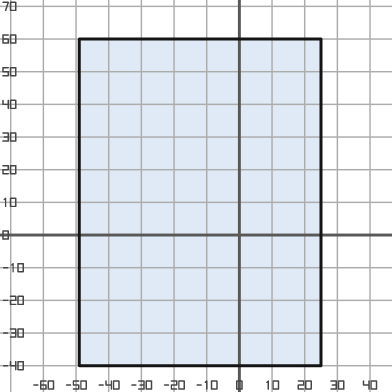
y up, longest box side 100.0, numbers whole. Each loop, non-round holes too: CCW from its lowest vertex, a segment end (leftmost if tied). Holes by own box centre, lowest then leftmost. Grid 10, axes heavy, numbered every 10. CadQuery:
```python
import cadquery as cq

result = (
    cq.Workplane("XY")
    .moveTo(-49.0, -40.0)
    .lineTo(25.0, -40.0)
    .lineTo(25.0, 60.0)
    .lineTo(-49.0, 60.0)
    .close()
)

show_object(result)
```